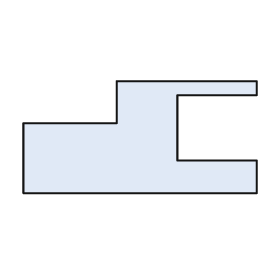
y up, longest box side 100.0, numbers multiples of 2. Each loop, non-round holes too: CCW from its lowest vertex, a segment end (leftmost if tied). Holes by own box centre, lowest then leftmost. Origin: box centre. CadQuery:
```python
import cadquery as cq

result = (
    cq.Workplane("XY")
    .moveTo(-50.0, -24.0)
    .lineTo(50.0, -24.0)
    .lineTo(50.0, -10.0)
    .lineTo(16.0, -10.0)
    .lineTo(16.0, 18.0)
    .lineTo(50.0, 18.0)
    .lineTo(50.0, 24.0)
    .lineTo(-10.0, 24.0)
    .lineTo(-10.0, 6.0)
    .lineTo(-50.0, 6.0)
    .close()
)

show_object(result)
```